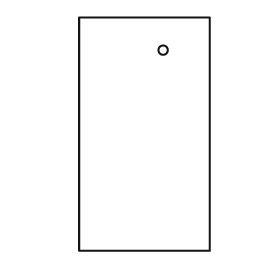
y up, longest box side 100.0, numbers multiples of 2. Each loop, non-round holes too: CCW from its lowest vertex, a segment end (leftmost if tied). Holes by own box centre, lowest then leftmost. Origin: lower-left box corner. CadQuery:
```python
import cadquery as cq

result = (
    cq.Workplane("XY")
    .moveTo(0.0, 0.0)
    .lineTo(56.0, 0.0)
    .lineTo(56.0, 100.0)
    .lineTo(0.0, 100.0)
    .close()
    .moveTo(36.0, 86.0)
    .circle(2.0)
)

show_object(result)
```